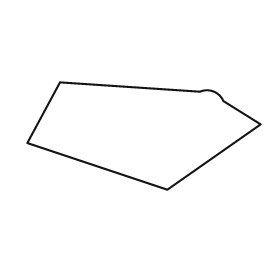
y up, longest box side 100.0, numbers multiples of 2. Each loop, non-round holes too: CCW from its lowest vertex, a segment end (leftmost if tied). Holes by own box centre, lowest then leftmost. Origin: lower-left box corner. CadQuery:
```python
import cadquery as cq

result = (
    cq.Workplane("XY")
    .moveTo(60.0, 0.0)
    .lineTo(100.0, 28.0)
    .lineTo(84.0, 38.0)
    .threePointArc((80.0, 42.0), (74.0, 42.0))
    .lineTo(14.0, 46.0)
    .lineTo(0.0, 20.0)
    .close()
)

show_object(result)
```